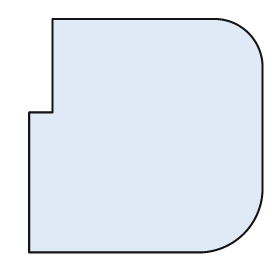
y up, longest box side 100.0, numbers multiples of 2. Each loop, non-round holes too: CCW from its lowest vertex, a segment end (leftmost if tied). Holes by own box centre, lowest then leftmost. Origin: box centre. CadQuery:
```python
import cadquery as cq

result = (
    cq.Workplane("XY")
    .moveTo(-50.0, -50.0)
    .lineTo(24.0, -50.0)
    .threePointArc((42.0, -42.0), (50.0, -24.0))
    .lineTo(50.0, 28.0)
    .threePointArc((44.0, 44.0), (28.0, 50.0))
    .lineTo(-40.0, 50.0)
    .lineTo(-40.0, 10.0)
    .lineTo(-50.0, 10.0)
    .close()
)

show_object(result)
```